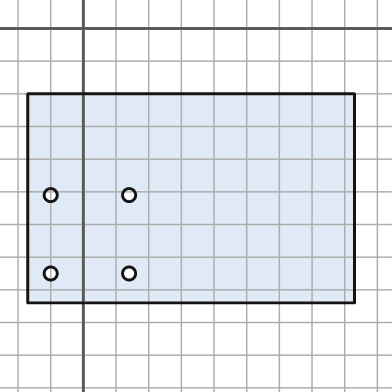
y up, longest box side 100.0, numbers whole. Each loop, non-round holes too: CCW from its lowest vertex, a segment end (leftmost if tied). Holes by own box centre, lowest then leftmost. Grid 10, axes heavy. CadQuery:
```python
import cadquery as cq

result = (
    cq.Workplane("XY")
    .moveTo(-17.0, -84.0)
    .lineTo(83.0, -84.0)
    .lineTo(83.0, -20.0)
    .lineTo(-17.0, -20.0)
    .close()
    .moveTo(-10.0, -75.0)
    .circle(2.0)
    .moveTo(14.0, -75.0)
    .circle(2.0)
    .moveTo(-10.0, -51.0)
    .circle(2.0)
    .moveTo(14.0, -51.0)
    .circle(2.0)
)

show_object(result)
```